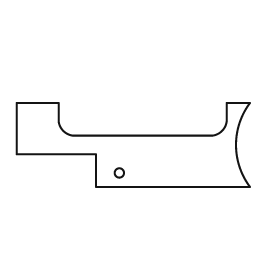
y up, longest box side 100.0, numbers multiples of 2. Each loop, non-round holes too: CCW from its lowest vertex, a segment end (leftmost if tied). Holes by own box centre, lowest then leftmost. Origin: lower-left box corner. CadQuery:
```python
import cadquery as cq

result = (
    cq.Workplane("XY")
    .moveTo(34.0, 0.0)
    .lineTo(100.0, 0.0)
    .threePointArc((94.0, 18.0), (100.0, 36.0))
    .lineTo(90.0, 36.0)
    .lineTo(90.0, 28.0)
    .threePointArc((88.0, 24.0), (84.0, 22.0))
    .lineTo(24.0, 22.0)
    .threePointArc((20.0, 24.0), (18.0, 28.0))
    .lineTo(18.0, 36.0)
    .lineTo(0.0, 36.0)
    .lineTo(0.0, 14.0)
    .lineTo(34.0, 14.0)
    .close()
    .moveTo(44.0, 6.0)
    .circle(2.0)
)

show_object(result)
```